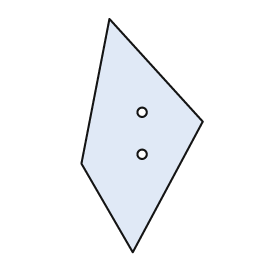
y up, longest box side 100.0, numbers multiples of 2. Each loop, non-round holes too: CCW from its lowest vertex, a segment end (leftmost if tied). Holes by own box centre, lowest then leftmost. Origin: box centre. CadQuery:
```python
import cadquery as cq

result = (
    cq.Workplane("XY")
    .moveTo(-4.0, -50.0)
    .lineTo(26.0, 6.0)
    .lineTo(-14.0, 50.0)
    .lineTo(-26.0, -12.0)
    .close()
    .moveTo(0.0, -8.0)
    .circle(2.0)
    .moveTo(0.0, 10.0)
    .circle(2.0)
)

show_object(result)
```